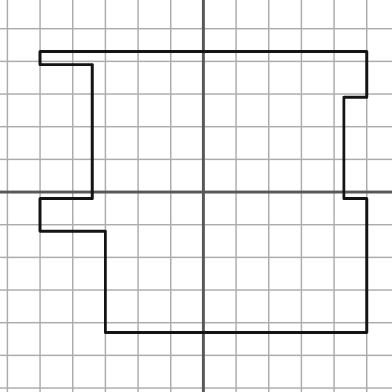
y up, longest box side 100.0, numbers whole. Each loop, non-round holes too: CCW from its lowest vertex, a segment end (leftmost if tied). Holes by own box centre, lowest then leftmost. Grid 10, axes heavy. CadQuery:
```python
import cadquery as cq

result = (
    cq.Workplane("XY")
    .moveTo(-30.0, -43.0)
    .lineTo(50.0, -43.0)
    .lineTo(50.0, -2.0)
    .lineTo(43.0, -2.0)
    .lineTo(43.0, 29.0)
    .lineTo(50.0, 29.0)
    .lineTo(50.0, 43.0)
    .lineTo(-50.0, 43.0)
    .lineTo(-50.0, 39.0)
    .lineTo(-34.0, 39.0)
    .lineTo(-34.0, -2.0)
    .lineTo(-50.0, -2.0)
    .lineTo(-50.0, -12.0)
    .lineTo(-30.0, -12.0)
    .close()
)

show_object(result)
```